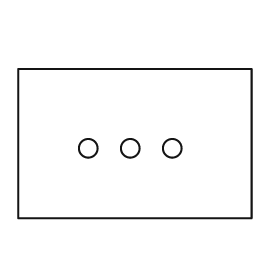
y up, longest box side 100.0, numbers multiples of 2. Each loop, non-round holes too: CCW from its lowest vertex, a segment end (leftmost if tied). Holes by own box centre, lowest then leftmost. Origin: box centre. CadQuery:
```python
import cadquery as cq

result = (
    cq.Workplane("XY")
    .moveTo(-50.0, -32.0)
    .lineTo(50.0, -32.0)
    .lineTo(50.0, 32.0)
    .lineTo(-50.0, 32.0)
    .close()
    .moveTo(-20.0, -2.0)
    .circle(4.0)
    .moveTo(-2.0, -2.0)
    .circle(4.0)
    .moveTo(16.0, -2.0)
    .circle(4.0)
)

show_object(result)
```